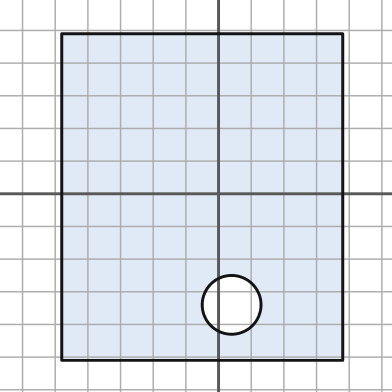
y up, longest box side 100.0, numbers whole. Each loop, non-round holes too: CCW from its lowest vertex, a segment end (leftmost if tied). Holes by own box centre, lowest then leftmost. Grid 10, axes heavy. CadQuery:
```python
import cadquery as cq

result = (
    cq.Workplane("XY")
    .moveTo(-48.0, -51.0)
    .lineTo(38.0, -51.0)
    .lineTo(38.0, 49.0)
    .lineTo(-48.0, 49.0)
    .close()
    .moveTo(4.0, -34.0)
    .circle(9.0)
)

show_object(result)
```